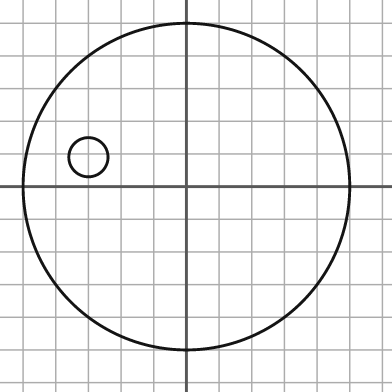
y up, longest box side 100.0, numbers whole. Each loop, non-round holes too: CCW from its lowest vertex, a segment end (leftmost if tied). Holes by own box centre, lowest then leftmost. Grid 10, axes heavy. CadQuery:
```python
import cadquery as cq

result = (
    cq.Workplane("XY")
    .moveTo(0.0, 0.0)
    .circle(50.0)
    .moveTo(-30.0, 9.0)
    .circle(6.0)
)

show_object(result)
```